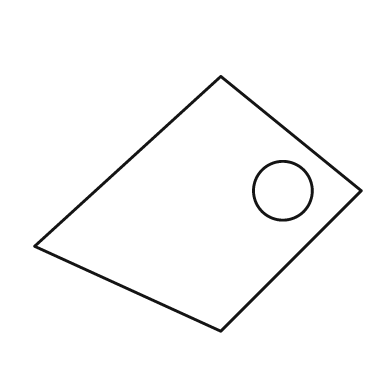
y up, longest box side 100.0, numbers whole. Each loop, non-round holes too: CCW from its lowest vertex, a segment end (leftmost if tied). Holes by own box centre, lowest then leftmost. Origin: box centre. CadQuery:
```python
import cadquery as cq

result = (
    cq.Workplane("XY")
    .moveTo(7.0, -39.0)
    .lineTo(50.0, 4.0)
    .lineTo(7.0, 39.0)
    .lineTo(-50.0, -13.0)
    .close()
    .moveTo(26.0, 4.0)
    .circle(9.0)
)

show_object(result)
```